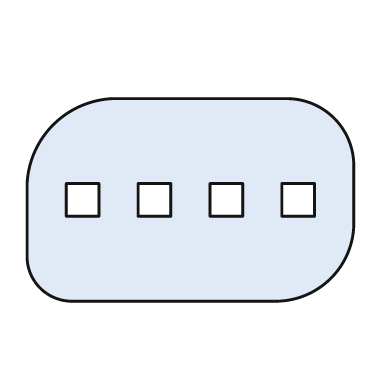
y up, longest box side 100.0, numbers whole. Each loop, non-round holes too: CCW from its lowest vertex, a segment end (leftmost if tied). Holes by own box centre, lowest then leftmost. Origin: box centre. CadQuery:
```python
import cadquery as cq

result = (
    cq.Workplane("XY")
    .moveTo(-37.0, -31.0)
    .lineTo(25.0, -31.0)
    .threePointArc((43.0, -24.0), (50.0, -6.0))
    .lineTo(50.0, 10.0)
    .threePointArc((44.0, 25.0), (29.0, 31.0))
    .lineTo(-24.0, 31.0)
    .threePointArc((-42.0, 23.0), (-50.0, 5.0))
    .lineTo(-50.0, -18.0)
    .threePointArc((-46.0, -27.0), (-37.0, -31.0))
    .close()
    .moveTo(-38.0, -5.0)
    .lineTo(-28.0, -5.0)
    .lineTo(-28.0, 5.0)
    .lineTo(-38.0, 5.0)
    .close()
    .moveTo(-16.0, -5.0)
    .lineTo(-6.0, -5.0)
    .lineTo(-6.0, 5.0)
    .lineTo(-16.0, 5.0)
    .close()
    .moveTo(6.0, -5.0)
    .lineTo(16.0, -5.0)
    .lineTo(16.0, 5.0)
    .lineTo(6.0, 5.0)
    .close()
    .moveTo(28.0, -5.0)
    .lineTo(38.0, -5.0)
    .lineTo(38.0, 5.0)
    .lineTo(28.0, 5.0)
    .close()
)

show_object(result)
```